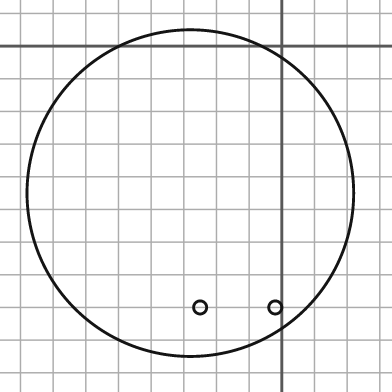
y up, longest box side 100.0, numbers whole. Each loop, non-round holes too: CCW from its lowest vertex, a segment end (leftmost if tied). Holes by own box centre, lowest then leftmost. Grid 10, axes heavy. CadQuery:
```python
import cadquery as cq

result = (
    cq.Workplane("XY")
    .moveTo(-28.0, -45.0)
    .circle(50.0)
    .moveTo(-25.0, -80.0)
    .circle(2.0)
    .moveTo(-2.0, -80.0)
    .circle(2.0)
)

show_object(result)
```